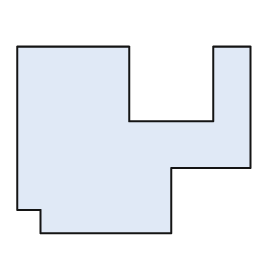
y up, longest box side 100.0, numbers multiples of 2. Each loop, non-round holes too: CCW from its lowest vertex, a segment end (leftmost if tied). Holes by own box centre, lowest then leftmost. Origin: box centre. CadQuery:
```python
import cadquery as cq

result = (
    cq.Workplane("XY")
    .moveTo(-40.0, -40.0)
    .lineTo(16.0, -40.0)
    .lineTo(16.0, -12.0)
    .lineTo(50.0, -12.0)
    .lineTo(50.0, 40.0)
    .lineTo(34.0, 40.0)
    .lineTo(34.0, 8.0)
    .lineTo(-2.0, 8.0)
    .lineTo(-2.0, 40.0)
    .lineTo(-50.0, 40.0)
    .lineTo(-50.0, -30.0)
    .lineTo(-40.0, -30.0)
    .close()
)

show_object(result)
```